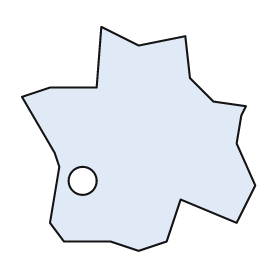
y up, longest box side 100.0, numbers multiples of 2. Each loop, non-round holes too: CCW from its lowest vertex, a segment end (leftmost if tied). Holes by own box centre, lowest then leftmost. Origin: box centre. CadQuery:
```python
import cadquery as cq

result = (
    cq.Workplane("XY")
    .moveTo(0.0, -48.0)
    .lineTo(12.0, -44.0)
    .lineTo(18.0, -26.0)
    .lineTo(42.0, -36.0)
    .lineTo(50.0, -20.0)
    .lineTo(42.0, -2.0)
    .lineTo(44.0, 10.0)
    .lineTo(46.0, 14.0)
    .lineTo(32.0, 16.0)
    .lineTo(22.0, 26.0)
    .lineTo(20.0, 44.0)
    .lineTo(0.0, 40.0)
    .lineTo(-16.0, 48.0)
    .lineTo(-18.0, 22.0)
    .lineTo(-38.0, 22.0)
    .lineTo(-50.0, 18.0)
    .lineTo(-36.0, -6.0)
    .lineTo(-34.0, -12.0)
    .lineTo(-38.0, -36.0)
    .lineTo(-32.0, -44.0)
    .lineTo(-12.0, -44.0)
    .close()
    .moveTo(-24.0, -18.0)
    .circle(6.0)
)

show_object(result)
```